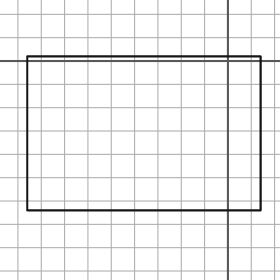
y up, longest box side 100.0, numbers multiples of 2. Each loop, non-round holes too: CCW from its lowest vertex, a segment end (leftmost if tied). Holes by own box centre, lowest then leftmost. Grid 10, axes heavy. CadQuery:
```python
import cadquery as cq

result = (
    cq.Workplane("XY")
    .moveTo(-86.0, -64.0)
    .lineTo(14.0, -64.0)
    .lineTo(14.0, 2.0)
    .lineTo(-86.0, 2.0)
    .close()
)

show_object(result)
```